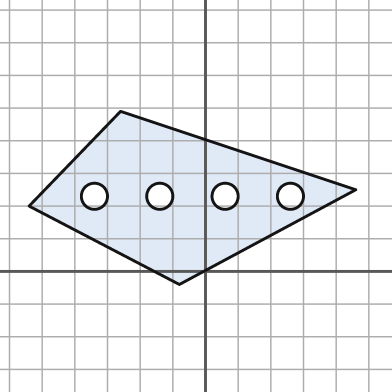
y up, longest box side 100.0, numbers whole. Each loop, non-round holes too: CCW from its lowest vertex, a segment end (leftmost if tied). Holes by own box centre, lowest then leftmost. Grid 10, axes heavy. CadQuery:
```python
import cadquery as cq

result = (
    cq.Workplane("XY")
    .moveTo(-8.0, -4.0)
    .lineTo(46.0, 25.0)
    .lineTo(-26.0, 49.0)
    .lineTo(-54.0, 20.0)
    .close()
    .moveTo(-34.0, 23.0)
    .circle(4.0)
    .moveTo(-14.0, 23.0)
    .circle(4.0)
    .moveTo(6.0, 23.0)
    .circle(4.0)
    .moveTo(26.0, 23.0)
    .circle(4.0)
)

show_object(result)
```